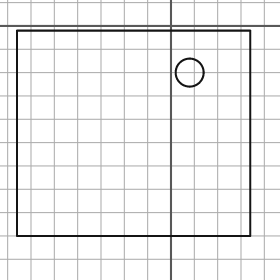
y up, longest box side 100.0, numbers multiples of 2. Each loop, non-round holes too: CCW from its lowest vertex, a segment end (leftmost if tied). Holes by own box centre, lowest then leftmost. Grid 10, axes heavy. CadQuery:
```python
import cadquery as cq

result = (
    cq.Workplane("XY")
    .moveTo(-66.0, -90.0)
    .lineTo(34.0, -90.0)
    .lineTo(34.0, -2.0)
    .lineTo(-66.0, -2.0)
    .close()
    .moveTo(8.0, -20.0)
    .circle(6.0)
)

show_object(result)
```